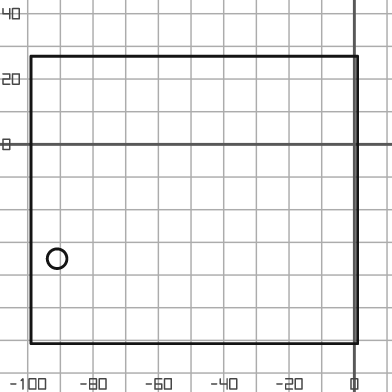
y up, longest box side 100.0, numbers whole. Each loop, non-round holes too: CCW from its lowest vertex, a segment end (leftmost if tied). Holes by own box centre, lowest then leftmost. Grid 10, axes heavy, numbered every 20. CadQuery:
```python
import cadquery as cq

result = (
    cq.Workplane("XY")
    .moveTo(-99.0, -61.0)
    .lineTo(1.0, -61.0)
    .lineTo(1.0, 27.0)
    .lineTo(-99.0, 27.0)
    .close()
    .moveTo(-91.0, -35.0)
    .circle(3.0)
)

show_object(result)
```